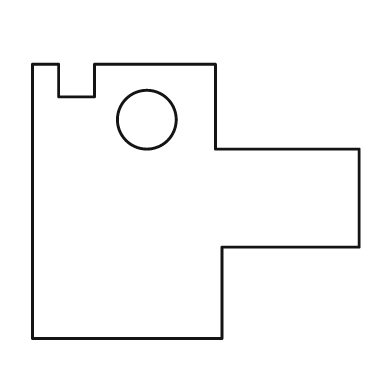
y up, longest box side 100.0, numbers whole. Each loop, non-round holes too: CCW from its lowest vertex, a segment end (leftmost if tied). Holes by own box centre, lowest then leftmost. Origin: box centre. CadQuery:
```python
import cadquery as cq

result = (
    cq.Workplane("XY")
    .moveTo(-50.0, -42.0)
    .lineTo(8.0, -42.0)
    .lineTo(8.0, -14.0)
    .lineTo(50.0, -14.0)
    .lineTo(50.0, 16.0)
    .lineTo(6.0, 16.0)
    .lineTo(6.0, 42.0)
    .lineTo(-31.0, 42.0)
    .lineTo(-31.0, 32.0)
    .lineTo(-42.0, 32.0)
    .lineTo(-42.0, 42.0)
    .lineTo(-50.0, 42.0)
    .close()
    .moveTo(-15.0, 25.0)
    .circle(9.0)
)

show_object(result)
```